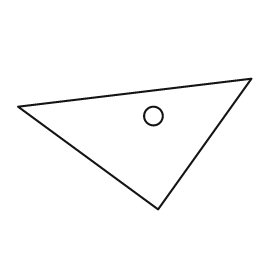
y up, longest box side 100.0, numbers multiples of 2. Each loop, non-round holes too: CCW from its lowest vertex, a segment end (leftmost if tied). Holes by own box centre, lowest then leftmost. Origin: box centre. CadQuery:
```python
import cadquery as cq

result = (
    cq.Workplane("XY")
    .moveTo(10.0, -28.0)
    .lineTo(50.0, 28.0)
    .lineTo(-50.0, 16.0)
    .close()
    .moveTo(8.0, 12.0)
    .circle(4.0)
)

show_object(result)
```